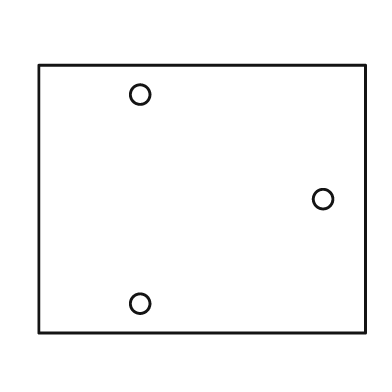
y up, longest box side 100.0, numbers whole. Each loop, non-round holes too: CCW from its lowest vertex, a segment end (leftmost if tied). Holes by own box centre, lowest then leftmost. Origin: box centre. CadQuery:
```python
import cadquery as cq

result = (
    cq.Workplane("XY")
    .moveTo(-50.0, -41.0)
    .lineTo(50.0, -41.0)
    .lineTo(50.0, 41.0)
    .lineTo(-50.0, 41.0)
    .close()
    .moveTo(-19.0, -32.0)
    .circle(3.0)
    .moveTo(37.0, 0.0)
    .circle(3.0)
    .moveTo(-19.0, 32.0)
    .circle(3.0)
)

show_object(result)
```